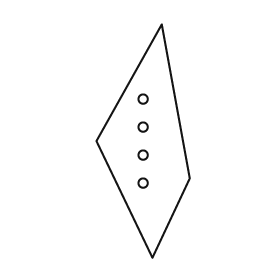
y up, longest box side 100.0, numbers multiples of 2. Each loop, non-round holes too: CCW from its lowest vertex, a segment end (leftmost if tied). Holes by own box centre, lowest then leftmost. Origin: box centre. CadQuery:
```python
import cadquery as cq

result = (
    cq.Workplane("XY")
    .moveTo(4.0, -50.0)
    .lineTo(20.0, -16.0)
    .lineTo(8.0, 50.0)
    .lineTo(-20.0, 0.0)
    .close()
    .moveTo(0.0, -18.0)
    .circle(2.0)
    .moveTo(0.0, -6.0)
    .circle(2.0)
    .moveTo(0.0, 6.0)
    .circle(2.0)
    .moveTo(0.0, 18.0)
    .circle(2.0)
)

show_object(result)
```